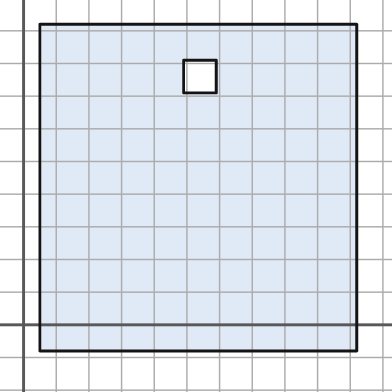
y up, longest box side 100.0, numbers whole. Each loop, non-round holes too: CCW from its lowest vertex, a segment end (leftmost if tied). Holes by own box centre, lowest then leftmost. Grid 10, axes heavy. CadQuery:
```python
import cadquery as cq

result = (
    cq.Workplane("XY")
    .moveTo(5.0, -8.0)
    .lineTo(102.0, -8.0)
    .lineTo(102.0, 92.0)
    .lineTo(5.0, 92.0)
    .close()
    .moveTo(49.0, 71.0)
    .lineTo(59.0, 71.0)
    .lineTo(59.0, 81.0)
    .lineTo(49.0, 81.0)
    .close()
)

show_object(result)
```